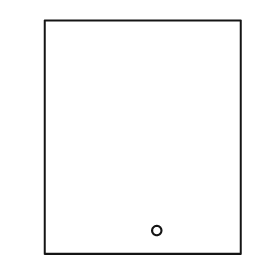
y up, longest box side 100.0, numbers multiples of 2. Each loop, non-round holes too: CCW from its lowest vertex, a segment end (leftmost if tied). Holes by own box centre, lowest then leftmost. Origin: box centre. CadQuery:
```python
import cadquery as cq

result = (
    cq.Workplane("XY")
    .moveTo(-42.0, -50.0)
    .lineTo(42.0, -50.0)
    .lineTo(42.0, 50.0)
    .lineTo(-42.0, 50.0)
    .close()
    .moveTo(6.0, -40.0)
    .circle(2.0)
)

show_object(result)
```